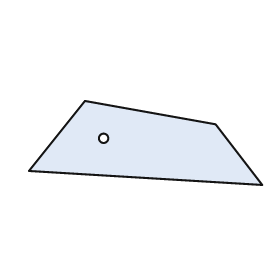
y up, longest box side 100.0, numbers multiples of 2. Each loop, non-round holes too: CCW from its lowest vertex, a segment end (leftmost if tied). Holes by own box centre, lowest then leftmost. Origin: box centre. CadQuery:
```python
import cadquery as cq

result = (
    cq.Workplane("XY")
    .moveTo(50.0, -18.0)
    .lineTo(30.0, 8.0)
    .lineTo(-26.0, 18.0)
    .lineTo(-50.0, -12.0)
    .close()
    .moveTo(-18.0, 2.0)
    .circle(2.0)
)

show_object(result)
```